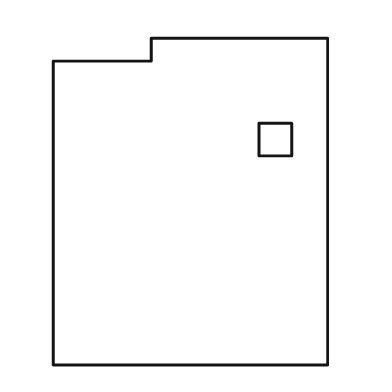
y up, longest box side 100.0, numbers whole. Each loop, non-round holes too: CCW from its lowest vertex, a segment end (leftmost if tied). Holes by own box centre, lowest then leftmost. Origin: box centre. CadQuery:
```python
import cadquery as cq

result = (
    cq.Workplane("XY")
    .moveTo(-42.0, -50.0)
    .lineTo(42.0, -50.0)
    .lineTo(42.0, 50.0)
    .lineTo(-12.0, 50.0)
    .lineTo(-12.0, 43.0)
    .lineTo(-42.0, 43.0)
    .close()
    .moveTo(21.0, 14.0)
    .lineTo(31.0, 14.0)
    .lineTo(31.0, 24.0)
    .lineTo(21.0, 24.0)
    .close()
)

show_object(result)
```